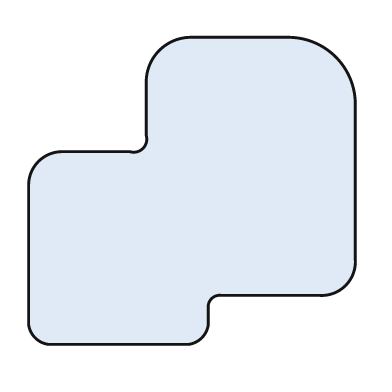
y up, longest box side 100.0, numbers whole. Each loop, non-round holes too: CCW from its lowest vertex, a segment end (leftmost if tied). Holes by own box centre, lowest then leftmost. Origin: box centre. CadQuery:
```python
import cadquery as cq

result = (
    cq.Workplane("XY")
    .moveTo(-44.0, -47.0)
    .lineTo(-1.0, -47.0)
    .threePointArc((3.0, -45.0), (5.0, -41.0))
    .lineTo(5.0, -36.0)
    .threePointArc((6.0, -33.0), (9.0, -32.0))
    .lineTo(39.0, -32.0)
    .threePointArc((47.0, -29.0), (50.0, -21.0))
    .lineTo(50.0, 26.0)
    .threePointArc((44.0, 41.0), (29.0, 47.0))
    .lineTo(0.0, 47.0)
    .threePointArc((-10.0, 43.0), (-14.0, 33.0))
    .lineTo(-14.0, 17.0)
    .threePointArc((-15.0, 13.0), (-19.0, 12.0))
    .lineTo(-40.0, 12.0)
    .threePointArc((-47.0, 9.0), (-50.0, 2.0))
    .lineTo(-50.0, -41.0)
    .threePointArc((-48.0, -45.0), (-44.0, -47.0))
    .close()
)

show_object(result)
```